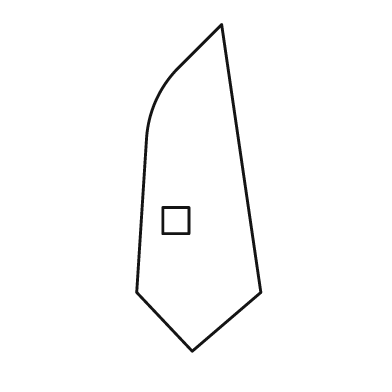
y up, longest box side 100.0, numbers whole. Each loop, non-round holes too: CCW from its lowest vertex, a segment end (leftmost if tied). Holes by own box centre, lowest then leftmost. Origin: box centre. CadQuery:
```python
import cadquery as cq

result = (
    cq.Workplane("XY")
    .moveTo(-2.0, -50.0)
    .lineTo(19.0, -32.0)
    .lineTo(7.0, 50.0)
    .lineTo(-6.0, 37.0)
    .threePointArc((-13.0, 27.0), (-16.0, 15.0))
    .lineTo(-19.0, -32.0)
    .close()
    .moveTo(-11.0, -14.0)
    .lineTo(-3.0, -14.0)
    .lineTo(-3.0, -6.0)
    .lineTo(-11.0, -6.0)
    .close()
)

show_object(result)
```